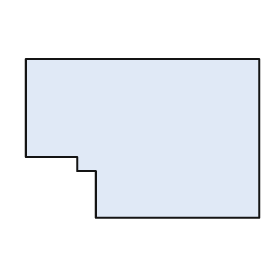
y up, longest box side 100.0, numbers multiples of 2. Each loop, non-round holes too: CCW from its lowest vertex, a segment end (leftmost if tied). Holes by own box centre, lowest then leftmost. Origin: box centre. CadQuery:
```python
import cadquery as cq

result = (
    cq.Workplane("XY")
    .moveTo(-20.0, -34.0)
    .lineTo(50.0, -34.0)
    .lineTo(50.0, 34.0)
    .lineTo(-50.0, 34.0)
    .lineTo(-50.0, -8.0)
    .lineTo(-28.0, -8.0)
    .lineTo(-28.0, -14.0)
    .lineTo(-20.0, -14.0)
    .close()
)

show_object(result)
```